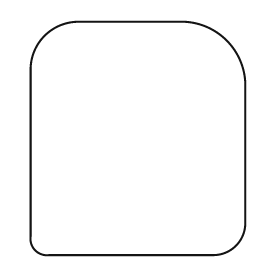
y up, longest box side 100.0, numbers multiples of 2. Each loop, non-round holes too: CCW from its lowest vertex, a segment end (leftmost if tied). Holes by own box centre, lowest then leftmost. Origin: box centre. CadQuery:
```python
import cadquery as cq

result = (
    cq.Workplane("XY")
    .moveTo(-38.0, -50.0)
    .lineTo(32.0, -50.0)
    .threePointArc((42.0, -46.0), (46.0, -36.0))
    .lineTo(46.0, 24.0)
    .threePointArc((38.0, 42.0), (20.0, 50.0))
    .lineTo(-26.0, 50.0)
    .threePointArc((-40.0, 44.0), (-46.0, 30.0))
    .lineTo(-46.0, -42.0)
    .threePointArc((-44.0, -48.0), (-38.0, -50.0))
    .close()
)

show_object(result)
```